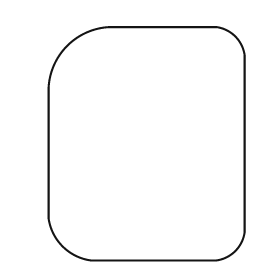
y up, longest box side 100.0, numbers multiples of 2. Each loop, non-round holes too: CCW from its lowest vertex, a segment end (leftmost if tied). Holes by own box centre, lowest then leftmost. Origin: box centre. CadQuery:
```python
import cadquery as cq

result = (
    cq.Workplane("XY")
    .moveTo(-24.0, -50.0)
    .lineTo(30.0, -50.0)
    .threePointArc((38.0, -46.0), (42.0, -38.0))
    .lineTo(42.0, 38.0)
    .threePointArc((38.0, 46.0), (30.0, 50.0))
    .lineTo(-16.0, 50.0)
    .threePointArc((-34.0, 42.0), (-42.0, 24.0))
    .lineTo(-42.0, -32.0)
    .threePointArc((-36.0, -44.0), (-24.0, -50.0))
    .close()
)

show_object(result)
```